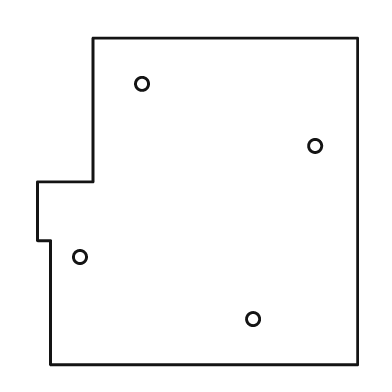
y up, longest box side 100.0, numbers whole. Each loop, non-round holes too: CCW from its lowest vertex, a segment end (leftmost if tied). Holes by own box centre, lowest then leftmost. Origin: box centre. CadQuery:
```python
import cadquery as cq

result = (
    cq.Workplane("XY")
    .moveTo(-45.0, -50.0)
    .lineTo(49.0, -50.0)
    .lineTo(49.0, 50.0)
    .lineTo(-32.0, 50.0)
    .lineTo(-32.0, 6.0)
    .lineTo(-49.0, 6.0)
    .lineTo(-49.0, -12.0)
    .lineTo(-45.0, -12.0)
    .close()
    .moveTo(17.0, -36.0)
    .circle(2.0)
    .moveTo(-36.0, -17.0)
    .circle(2.0)
    .moveTo(36.0, 17.0)
    .circle(2.0)
    .moveTo(-17.0, 36.0)
    .circle(2.0)
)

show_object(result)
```